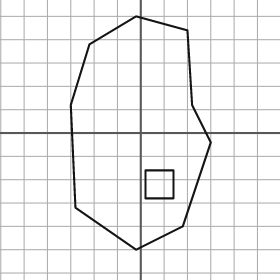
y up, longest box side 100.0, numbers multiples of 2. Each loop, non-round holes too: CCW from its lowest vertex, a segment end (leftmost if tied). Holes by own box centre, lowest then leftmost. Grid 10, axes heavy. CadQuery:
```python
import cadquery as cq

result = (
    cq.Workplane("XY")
    .moveTo(-2.0, -50.0)
    .lineTo(18.0, -40.0)
    .lineTo(30.0, -4.0)
    .lineTo(22.0, 12.0)
    .lineTo(20.0, 44.0)
    .lineTo(-2.0, 50.0)
    .lineTo(-22.0, 38.0)
    .lineTo(-30.0, 12.0)
    .lineTo(-28.0, -32.0)
    .close()
    .moveTo(2.0, -28.0)
    .lineTo(14.0, -28.0)
    .lineTo(14.0, -16.0)
    .lineTo(2.0, -16.0)
    .close()
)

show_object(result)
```